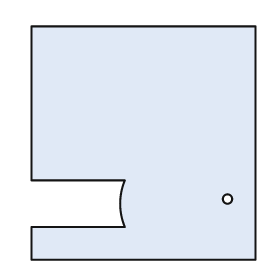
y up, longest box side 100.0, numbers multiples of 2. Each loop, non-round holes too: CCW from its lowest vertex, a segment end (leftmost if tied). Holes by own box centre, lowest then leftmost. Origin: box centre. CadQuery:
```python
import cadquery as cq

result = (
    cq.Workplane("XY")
    .moveTo(-48.0, -50.0)
    .lineTo(48.0, -50.0)
    .lineTo(48.0, 50.0)
    .lineTo(-48.0, 50.0)
    .lineTo(-48.0, -16.0)
    .lineTo(-8.0, -16.0)
    .threePointArc((-10.0, -26.0), (-8.0, -36.0))
    .lineTo(-48.0, -36.0)
    .close()
    .moveTo(36.0, -24.0)
    .circle(2.0)
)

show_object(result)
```